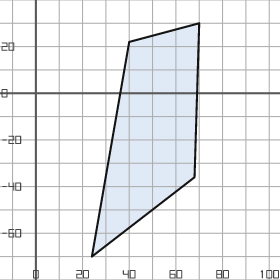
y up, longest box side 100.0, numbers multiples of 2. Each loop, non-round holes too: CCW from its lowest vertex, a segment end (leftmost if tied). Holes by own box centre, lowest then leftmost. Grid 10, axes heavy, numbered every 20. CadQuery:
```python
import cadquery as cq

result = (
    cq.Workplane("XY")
    .moveTo(24.0, -70.0)
    .lineTo(68.0, -36.0)
    .lineTo(70.0, 30.0)
    .lineTo(40.0, 22.0)
    .close()
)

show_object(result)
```